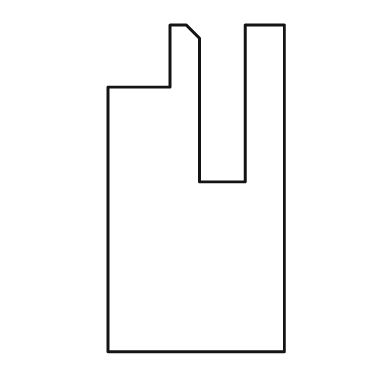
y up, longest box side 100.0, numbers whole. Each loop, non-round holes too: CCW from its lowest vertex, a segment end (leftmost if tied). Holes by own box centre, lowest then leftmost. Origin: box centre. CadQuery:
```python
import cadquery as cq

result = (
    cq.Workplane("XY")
    .moveTo(-27.0, -50.0)
    .lineTo(27.0, -50.0)
    .lineTo(27.0, 50.0)
    .lineTo(15.0, 50.0)
    .lineTo(15.0, 2.0)
    .lineTo(1.0, 2.0)
    .lineTo(1.0, 46.0)
    .lineTo(-3.0, 50.0)
    .lineTo(-8.0, 50.0)
    .lineTo(-8.0, 31.0)
    .lineTo(-27.0, 31.0)
    .close()
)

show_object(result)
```